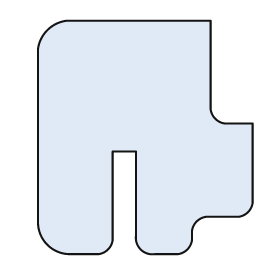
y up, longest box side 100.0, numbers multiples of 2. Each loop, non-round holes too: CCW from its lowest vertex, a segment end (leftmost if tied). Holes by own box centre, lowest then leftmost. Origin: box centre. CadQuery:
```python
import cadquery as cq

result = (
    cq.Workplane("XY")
    .moveTo(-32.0, -50.0)
    .lineTo(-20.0, -50.0)
    .threePointArc((-16.0, -48.0), (-14.0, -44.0))
    .lineTo(-14.0, -6.0)
    .lineTo(-4.0, -6.0)
    .lineTo(-4.0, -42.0)
    .threePointArc((-2.0, -48.0), (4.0, -50.0))
    .lineTo(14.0, -50.0)
    .threePointArc((18.0, -48.0), (20.0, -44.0))
    .lineTo(20.0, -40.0)
    .threePointArc((22.0, -36.0), (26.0, -34.0))
    .lineTo(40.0, -34.0)
    .threePointArc((44.0, -32.0), (46.0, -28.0))
    .lineTo(46.0, 6.0)
    .lineTo(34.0, 6.0)
    .threePointArc((30.0, 8.0), (28.0, 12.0))
    .lineTo(28.0, 50.0)
    .lineTo(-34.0, 50.0)
    .threePointArc((-42.0, 46.0), (-46.0, 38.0))
    .lineTo(-46.0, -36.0)
    .threePointArc((-42.0, -46.0), (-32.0, -50.0))
    .close()
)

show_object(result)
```